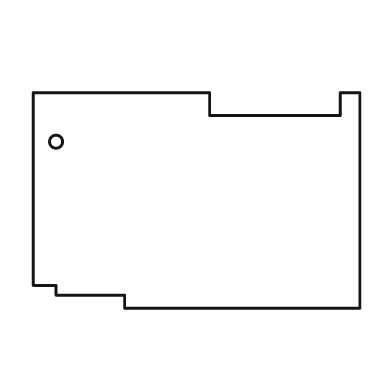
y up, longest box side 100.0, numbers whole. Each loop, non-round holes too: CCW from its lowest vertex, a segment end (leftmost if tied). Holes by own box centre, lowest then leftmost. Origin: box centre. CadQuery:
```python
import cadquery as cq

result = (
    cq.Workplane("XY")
    .moveTo(-22.0, -33.0)
    .lineTo(50.0, -33.0)
    .lineTo(50.0, 33.0)
    .lineTo(44.0, 33.0)
    .lineTo(44.0, 26.0)
    .lineTo(4.0, 26.0)
    .lineTo(4.0, 33.0)
    .lineTo(-50.0, 33.0)
    .lineTo(-50.0, -26.0)
    .lineTo(-43.0, -26.0)
    .lineTo(-43.0, -29.0)
    .lineTo(-22.0, -29.0)
    .close()
    .moveTo(-43.0, 18.0)
    .circle(2.0)
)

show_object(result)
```